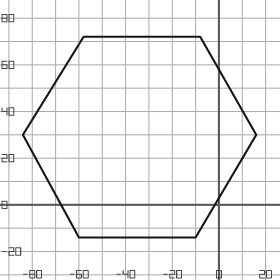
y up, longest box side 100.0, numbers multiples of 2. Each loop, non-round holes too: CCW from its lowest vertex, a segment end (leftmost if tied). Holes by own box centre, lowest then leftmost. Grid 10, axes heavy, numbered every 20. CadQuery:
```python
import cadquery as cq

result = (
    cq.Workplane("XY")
    .moveTo(-60.0, -14.0)
    .lineTo(-10.0, -14.0)
    .lineTo(16.0, 30.0)
    .lineTo(-8.0, 72.0)
    .lineTo(-58.0, 72.0)
    .lineTo(-84.0, 30.0)
    .close()
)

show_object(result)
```